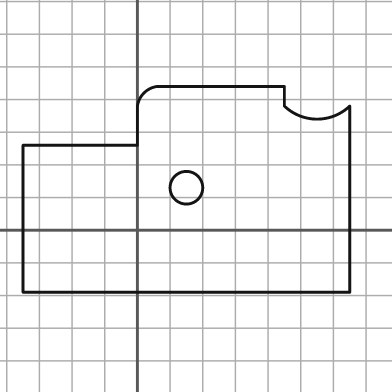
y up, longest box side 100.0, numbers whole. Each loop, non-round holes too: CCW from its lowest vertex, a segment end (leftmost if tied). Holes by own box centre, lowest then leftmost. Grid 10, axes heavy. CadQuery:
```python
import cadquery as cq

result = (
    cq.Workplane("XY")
    .moveTo(-35.0, -19.0)
    .lineTo(65.0, -19.0)
    .lineTo(65.0, 38.0)
    .threePointArc((55.0, 34.0), (45.0, 38.0))
    .lineTo(45.0, 44.0)
    .lineTo(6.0, 44.0)
    .threePointArc((2.0, 42.0), (0.0, 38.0))
    .lineTo(0.0, 26.0)
    .lineTo(-35.0, 26.0)
    .close()
    .moveTo(15.0, 13.0)
    .circle(5.0)
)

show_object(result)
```